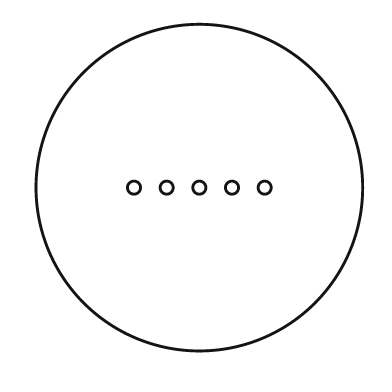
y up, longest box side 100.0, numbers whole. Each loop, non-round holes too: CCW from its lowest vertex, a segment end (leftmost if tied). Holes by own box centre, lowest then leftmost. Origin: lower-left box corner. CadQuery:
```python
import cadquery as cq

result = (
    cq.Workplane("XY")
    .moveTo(50.0, 50.0)
    .circle(50.0)
    .moveTo(30.0, 50.0)
    .circle(2.0)
    .moveTo(40.0, 50.0)
    .circle(2.0)
    .moveTo(50.0, 50.0)
    .circle(2.0)
    .moveTo(60.0, 50.0)
    .circle(2.0)
    .moveTo(70.0, 50.0)
    .circle(2.0)
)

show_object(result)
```